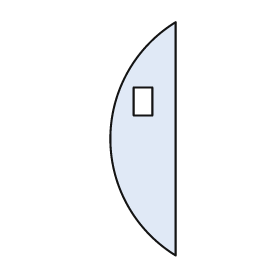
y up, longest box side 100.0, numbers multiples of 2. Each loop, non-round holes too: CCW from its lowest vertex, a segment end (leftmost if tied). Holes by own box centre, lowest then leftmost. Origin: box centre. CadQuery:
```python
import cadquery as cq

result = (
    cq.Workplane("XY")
    .moveTo(14.0, -50.0)
    .lineTo(14.0, 50.0)
    .threePointArc((-14.0, 0.0), (14.0, -50.0))
    .close()
    .moveTo(-4.0, 10.0)
    .lineTo(4.0, 10.0)
    .lineTo(4.0, 22.0)
    .lineTo(-4.0, 22.0)
    .close()
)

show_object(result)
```